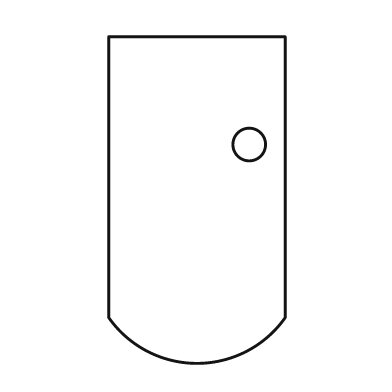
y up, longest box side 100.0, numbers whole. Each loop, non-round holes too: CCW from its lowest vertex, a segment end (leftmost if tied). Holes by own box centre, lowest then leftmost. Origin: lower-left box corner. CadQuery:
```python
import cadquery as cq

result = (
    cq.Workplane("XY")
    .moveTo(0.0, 14.0)
    .threePointArc((27.0, 0.0), (54.0, 14.0))
    .lineTo(54.0, 100.0)
    .lineTo(0.0, 100.0)
    .close()
    .moveTo(43.0, 67.0)
    .circle(5.0)
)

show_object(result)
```